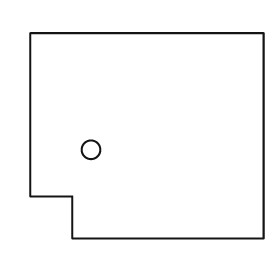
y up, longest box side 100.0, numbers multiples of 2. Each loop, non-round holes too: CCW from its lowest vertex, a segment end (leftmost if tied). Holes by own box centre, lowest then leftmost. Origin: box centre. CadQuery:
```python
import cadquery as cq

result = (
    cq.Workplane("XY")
    .moveTo(-32.0, -44.0)
    .lineTo(50.0, -44.0)
    .lineTo(50.0, 44.0)
    .lineTo(-50.0, 44.0)
    .lineTo(-50.0, -26.0)
    .lineTo(-32.0, -26.0)
    .close()
    .moveTo(-24.0, -6.0)
    .circle(4.0)
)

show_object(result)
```